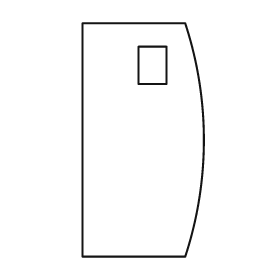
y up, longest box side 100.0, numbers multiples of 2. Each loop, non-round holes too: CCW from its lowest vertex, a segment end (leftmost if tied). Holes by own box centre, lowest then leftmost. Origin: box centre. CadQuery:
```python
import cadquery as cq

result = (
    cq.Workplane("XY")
    .moveTo(-26.0, -50.0)
    .lineTo(18.0, -50.0)
    .threePointArc((26.0, 0.0), (18.0, 50.0))
    .lineTo(-26.0, 50.0)
    .close()
    .moveTo(-2.0, 24.0)
    .lineTo(10.0, 24.0)
    .lineTo(10.0, 40.0)
    .lineTo(-2.0, 40.0)
    .close()
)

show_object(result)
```